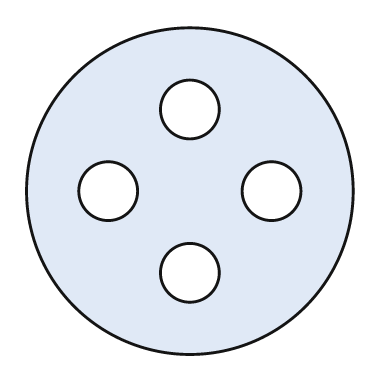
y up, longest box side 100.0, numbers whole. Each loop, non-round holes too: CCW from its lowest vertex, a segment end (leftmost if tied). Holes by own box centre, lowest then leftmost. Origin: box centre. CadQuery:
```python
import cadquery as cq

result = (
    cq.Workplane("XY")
    .moveTo(0.0, 0.0)
    .circle(50.0)
    .moveTo(0.0, -25.0)
    .circle(9.0)
    .moveTo(-25.0, 0.0)
    .circle(9.0)
    .moveTo(25.0, 0.0)
    .circle(9.0)
    .moveTo(0.0, 25.0)
    .circle(9.0)
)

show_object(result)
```